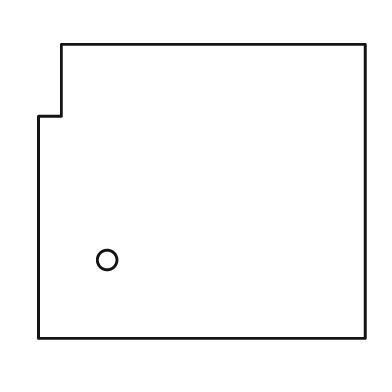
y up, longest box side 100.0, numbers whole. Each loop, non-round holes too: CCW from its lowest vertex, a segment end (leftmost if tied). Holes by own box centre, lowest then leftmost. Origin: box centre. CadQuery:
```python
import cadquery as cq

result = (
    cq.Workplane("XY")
    .moveTo(-50.0, -45.0)
    .lineTo(50.0, -45.0)
    .lineTo(50.0, 45.0)
    .lineTo(-43.0, 45.0)
    .lineTo(-43.0, 23.0)
    .lineTo(-50.0, 23.0)
    .close()
    .moveTo(-29.0, -21.0)
    .circle(3.0)
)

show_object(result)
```